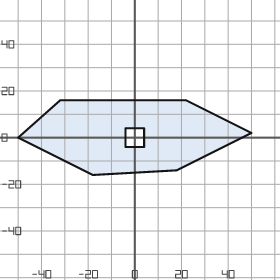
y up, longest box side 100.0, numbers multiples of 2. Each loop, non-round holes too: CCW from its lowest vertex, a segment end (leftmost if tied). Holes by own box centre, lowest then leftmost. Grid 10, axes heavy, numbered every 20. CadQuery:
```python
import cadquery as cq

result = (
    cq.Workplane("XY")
    .moveTo(-18.0, -16.0)
    .lineTo(18.0, -14.0)
    .lineTo(50.0, 2.0)
    .lineTo(22.0, 16.0)
    .lineTo(-32.0, 16.0)
    .lineTo(-50.0, 0.0)
    .close()
    .moveTo(-4.0, -4.0)
    .lineTo(4.0, -4.0)
    .lineTo(4.0, 4.0)
    .lineTo(-4.0, 4.0)
    .close()
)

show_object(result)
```